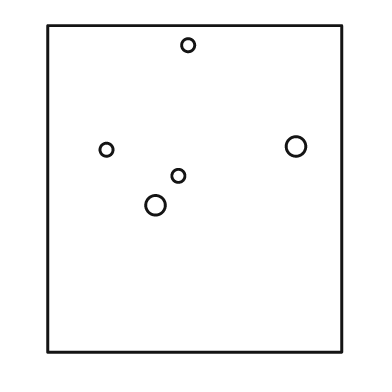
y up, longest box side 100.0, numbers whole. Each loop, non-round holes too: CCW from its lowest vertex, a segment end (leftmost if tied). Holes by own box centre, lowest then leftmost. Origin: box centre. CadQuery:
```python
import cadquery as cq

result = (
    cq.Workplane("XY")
    .moveTo(-45.0, -50.0)
    .lineTo(45.0, -50.0)
    .lineTo(45.0, 50.0)
    .lineTo(-45.0, 50.0)
    .close()
    .moveTo(-12.0, -5.0)
    .circle(3.0)
    .moveTo(-5.0, 4.0)
    .circle(2.0)
    .moveTo(-27.0, 12.0)
    .circle(2.0)
    .moveTo(31.0, 13.0)
    .circle(3.0)
    .moveTo(-2.0, 44.0)
    .circle(2.0)
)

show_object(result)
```